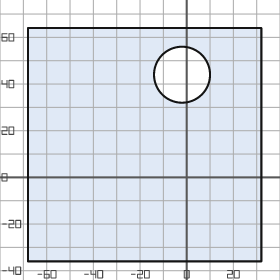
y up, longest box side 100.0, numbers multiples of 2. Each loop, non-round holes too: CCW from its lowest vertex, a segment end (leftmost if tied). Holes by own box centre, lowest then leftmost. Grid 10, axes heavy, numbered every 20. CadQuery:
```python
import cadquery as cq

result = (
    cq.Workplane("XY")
    .moveTo(-68.0, -36.0)
    .lineTo(32.0, -36.0)
    .lineTo(32.0, 64.0)
    .lineTo(-68.0, 64.0)
    .close()
    .moveTo(-2.0, 44.0)
    .circle(12.0)
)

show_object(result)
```